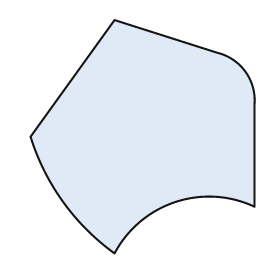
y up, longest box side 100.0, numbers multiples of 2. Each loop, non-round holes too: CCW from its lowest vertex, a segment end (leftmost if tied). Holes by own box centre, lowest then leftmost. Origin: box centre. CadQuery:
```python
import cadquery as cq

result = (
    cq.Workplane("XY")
    .moveTo(-12.0, -50.0)
    .threePointArc((14.0, -28.0), (48.0, -30.0))
    .lineTo(48.0, 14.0)
    .threePointArc((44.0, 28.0), (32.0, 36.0))
    .lineTo(-12.0, 50.0)
    .lineTo(-48.0, 0.0)
    .threePointArc((-34.0, -28.0), (-12.0, -50.0))
    .close()
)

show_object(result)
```